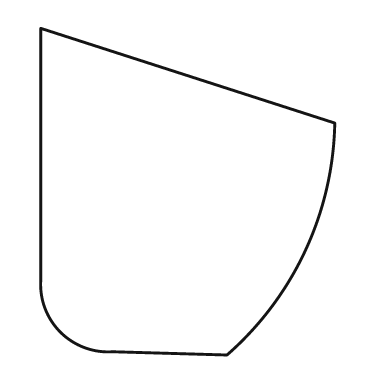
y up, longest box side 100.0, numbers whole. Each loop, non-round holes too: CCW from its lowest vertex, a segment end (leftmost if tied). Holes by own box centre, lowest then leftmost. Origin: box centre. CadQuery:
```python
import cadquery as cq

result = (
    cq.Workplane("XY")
    .moveTo(12.0, -50.0)
    .threePointArc((36.0, -18.0), (45.0, 21.0))
    .lineTo(-45.0, 50.0)
    .lineTo(-45.0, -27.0)
    .threePointArc((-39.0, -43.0), (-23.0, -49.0))
    .close()
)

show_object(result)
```